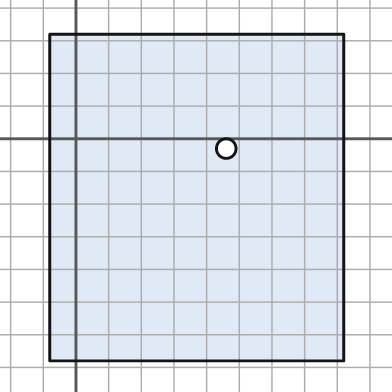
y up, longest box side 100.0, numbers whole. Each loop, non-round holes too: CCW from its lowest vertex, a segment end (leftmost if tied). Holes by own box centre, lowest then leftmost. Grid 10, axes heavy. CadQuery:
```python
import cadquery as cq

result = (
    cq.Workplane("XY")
    .moveTo(-8.0, -68.0)
    .lineTo(82.0, -68.0)
    .lineTo(82.0, 32.0)
    .lineTo(-8.0, 32.0)
    .close()
    .moveTo(46.0, -3.0)
    .circle(3.0)
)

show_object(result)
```